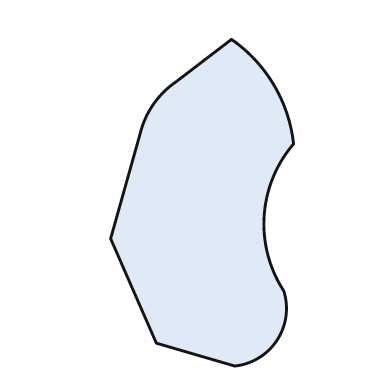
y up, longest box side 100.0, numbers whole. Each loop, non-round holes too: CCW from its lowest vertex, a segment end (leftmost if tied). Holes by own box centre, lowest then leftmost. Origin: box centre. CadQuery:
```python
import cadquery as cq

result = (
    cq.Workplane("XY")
    .moveTo(10.0, -50.0)
    .threePointArc((23.0, -42.0), (25.0, -27.0))
    .threePointArc((19.0, -4.0), (28.0, 18.0))
    .threePointArc((22.0, 36.0), (9.0, 50.0))
    .lineTo(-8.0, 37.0)
    .threePointArc((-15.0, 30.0), (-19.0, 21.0))
    .lineTo(-28.0, -11.0)
    .lineTo(-14.0, -43.0)
    .close()
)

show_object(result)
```